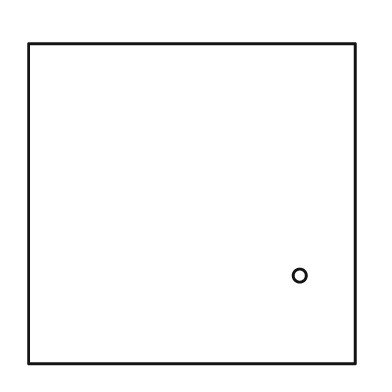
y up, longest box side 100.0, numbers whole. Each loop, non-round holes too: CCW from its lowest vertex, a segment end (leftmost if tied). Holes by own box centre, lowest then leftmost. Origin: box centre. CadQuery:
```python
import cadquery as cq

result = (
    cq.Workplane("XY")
    .moveTo(-50.0, -49.0)
    .lineTo(50.0, -49.0)
    .lineTo(50.0, 49.0)
    .lineTo(-50.0, 49.0)
    .close()
    .moveTo(33.0, -22.0)
    .circle(2.0)
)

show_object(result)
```